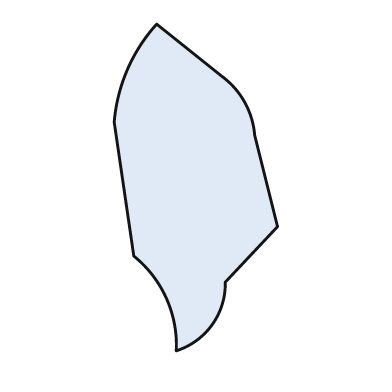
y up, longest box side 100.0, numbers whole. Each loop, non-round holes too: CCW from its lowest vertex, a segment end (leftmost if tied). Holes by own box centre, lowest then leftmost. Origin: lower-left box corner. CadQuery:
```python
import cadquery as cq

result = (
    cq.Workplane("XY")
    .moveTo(19.0, 0.0)
    .threePointArc((30.0, 8.0), (34.0, 21.0))
    .lineTo(50.0, 38.0)
    .lineTo(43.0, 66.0)
    .threePointArc((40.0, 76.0), (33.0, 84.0))
    .lineTo(13.0, 100.0)
    .threePointArc((4.0, 86.0), (0.0, 70.0))
    .lineTo(6.0, 29.0)
    .threePointArc((16.0, 16.0), (19.0, 0.0))
    .close()
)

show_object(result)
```